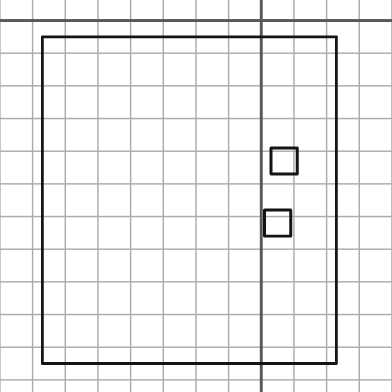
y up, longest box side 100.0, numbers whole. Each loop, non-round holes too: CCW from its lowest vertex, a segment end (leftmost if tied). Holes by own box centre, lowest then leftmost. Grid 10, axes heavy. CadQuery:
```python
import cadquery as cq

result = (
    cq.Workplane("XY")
    .moveTo(-67.0, -105.0)
    .lineTo(23.0, -105.0)
    .lineTo(23.0, -5.0)
    .lineTo(-67.0, -5.0)
    .close()
    .moveTo(1.0, -66.0)
    .lineTo(9.0, -66.0)
    .lineTo(9.0, -58.0)
    .lineTo(1.0, -58.0)
    .close()
    .moveTo(3.0, -47.0)
    .lineTo(11.0, -47.0)
    .lineTo(11.0, -39.0)
    .lineTo(3.0, -39.0)
    .close()
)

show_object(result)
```